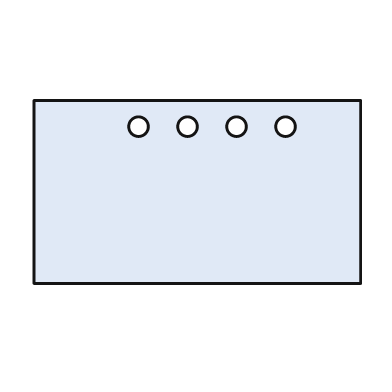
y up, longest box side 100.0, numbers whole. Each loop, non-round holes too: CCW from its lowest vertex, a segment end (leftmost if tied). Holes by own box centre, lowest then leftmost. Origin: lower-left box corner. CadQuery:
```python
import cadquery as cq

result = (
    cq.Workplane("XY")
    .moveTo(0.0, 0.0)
    .lineTo(100.0, 0.0)
    .lineTo(100.0, 56.0)
    .lineTo(0.0, 56.0)
    .close()
    .moveTo(32.0, 48.0)
    .circle(3.0)
    .moveTo(47.0, 48.0)
    .circle(3.0)
    .moveTo(62.0, 48.0)
    .circle(3.0)
    .moveTo(77.0, 48.0)
    .circle(3.0)
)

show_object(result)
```